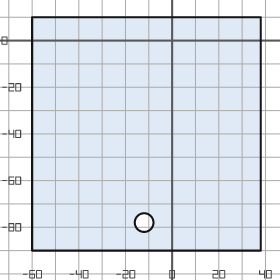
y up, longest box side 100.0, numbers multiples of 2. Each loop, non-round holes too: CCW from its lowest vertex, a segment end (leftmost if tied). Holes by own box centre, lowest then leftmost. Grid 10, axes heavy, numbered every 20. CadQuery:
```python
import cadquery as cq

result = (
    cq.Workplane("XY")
    .moveTo(-60.0, -90.0)
    .lineTo(38.0, -90.0)
    .lineTo(38.0, 10.0)
    .lineTo(-60.0, 10.0)
    .close()
    .moveTo(-12.0, -78.0)
    .circle(4.0)
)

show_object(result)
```